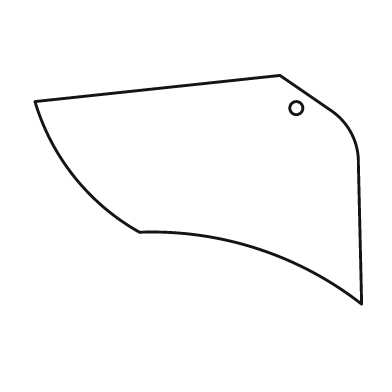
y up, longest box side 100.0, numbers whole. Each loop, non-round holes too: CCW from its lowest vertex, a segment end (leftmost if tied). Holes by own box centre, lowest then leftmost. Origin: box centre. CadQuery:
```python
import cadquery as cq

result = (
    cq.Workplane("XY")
    .moveTo(50.0, -35.0)
    .lineTo(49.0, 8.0)
    .threePointArc((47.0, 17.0), (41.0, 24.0))
    .lineTo(25.0, 35.0)
    .lineTo(-50.0, 27.0)
    .threePointArc((-38.0, 4.0), (-18.0, -13.0))
    .threePointArc((18.0, -18.0), (50.0, -35.0))
    .close()
    .moveTo(30.0, 25.0)
    .circle(2.0)
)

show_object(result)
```